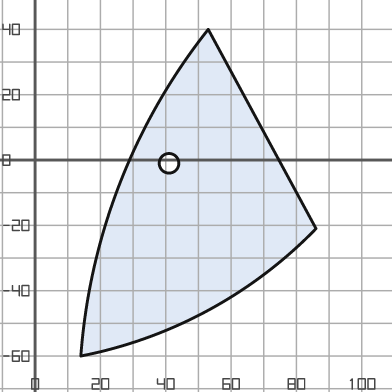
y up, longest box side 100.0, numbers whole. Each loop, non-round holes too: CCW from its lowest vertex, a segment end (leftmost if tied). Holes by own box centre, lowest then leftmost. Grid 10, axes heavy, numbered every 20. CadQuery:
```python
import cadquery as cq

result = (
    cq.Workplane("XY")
    .moveTo(14.0, -60.0)
    .threePointArc((53.0, -46.0), (86.0, -21.0))
    .lineTo(53.0, 40.0)
    .threePointArc((26.0, -7.0), (14.0, -60.0))
    .close()
    .moveTo(41.0, -1.0)
    .circle(3.0)
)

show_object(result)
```